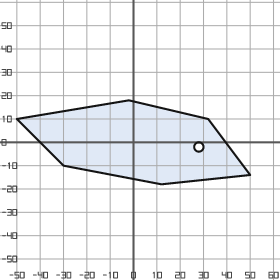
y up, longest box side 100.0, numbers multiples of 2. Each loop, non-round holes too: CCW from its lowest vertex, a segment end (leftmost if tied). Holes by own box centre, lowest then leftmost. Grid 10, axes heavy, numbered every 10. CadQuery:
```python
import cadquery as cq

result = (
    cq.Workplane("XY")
    .moveTo(12.0, -18.0)
    .lineTo(50.0, -14.0)
    .lineTo(32.0, 10.0)
    .lineTo(-2.0, 18.0)
    .lineTo(-50.0, 10.0)
    .lineTo(-30.0, -10.0)
    .close()
    .moveTo(28.0, -2.0)
    .circle(2.0)
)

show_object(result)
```